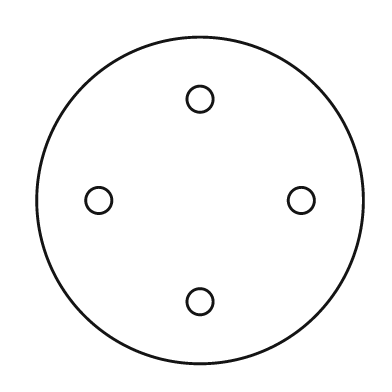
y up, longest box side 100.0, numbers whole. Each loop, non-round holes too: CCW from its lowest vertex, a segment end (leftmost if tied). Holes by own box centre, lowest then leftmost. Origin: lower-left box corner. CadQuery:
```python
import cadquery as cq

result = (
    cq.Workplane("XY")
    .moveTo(50.0, 50.0)
    .circle(50.0)
    .moveTo(50.0, 19.0)
    .circle(4.0)
    .moveTo(19.0, 50.0)
    .circle(4.0)
    .moveTo(81.0, 50.0)
    .circle(4.0)
    .moveTo(50.0, 81.0)
    .circle(4.0)
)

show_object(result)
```